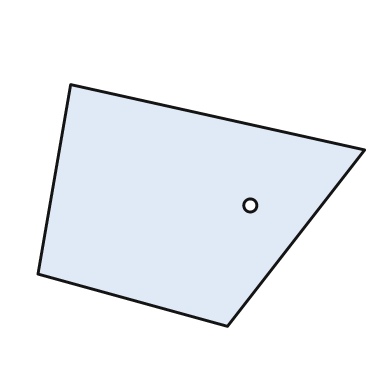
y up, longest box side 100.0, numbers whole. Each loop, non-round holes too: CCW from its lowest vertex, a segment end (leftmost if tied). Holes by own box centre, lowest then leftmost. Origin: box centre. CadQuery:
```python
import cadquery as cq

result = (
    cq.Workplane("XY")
    .moveTo(8.0, -37.0)
    .lineTo(50.0, 17.0)
    .lineTo(-40.0, 37.0)
    .lineTo(-50.0, -21.0)
    .close()
    .moveTo(15.0, 0.0)
    .circle(2.0)
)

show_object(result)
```